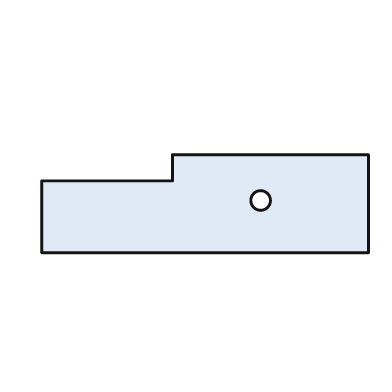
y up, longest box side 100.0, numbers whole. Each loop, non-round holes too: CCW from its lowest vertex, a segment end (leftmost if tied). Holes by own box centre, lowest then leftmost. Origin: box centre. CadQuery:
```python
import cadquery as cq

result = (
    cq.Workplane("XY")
    .moveTo(-50.0, -15.0)
    .lineTo(50.0, -15.0)
    .lineTo(50.0, 15.0)
    .lineTo(-10.0, 15.0)
    .lineTo(-10.0, 7.0)
    .lineTo(-50.0, 7.0)
    .close()
    .moveTo(17.0, 1.0)
    .circle(3.0)
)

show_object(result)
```